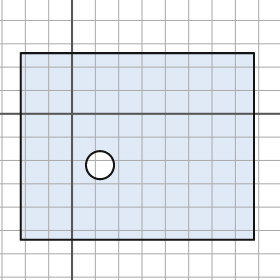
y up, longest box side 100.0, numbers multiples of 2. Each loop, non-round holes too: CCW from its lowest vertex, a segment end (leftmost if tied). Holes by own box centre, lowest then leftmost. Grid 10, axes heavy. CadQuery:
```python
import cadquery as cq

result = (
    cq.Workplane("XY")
    .moveTo(-22.0, -54.0)
    .lineTo(78.0, -54.0)
    .lineTo(78.0, 26.0)
    .lineTo(-22.0, 26.0)
    .close()
    .moveTo(12.0, -22.0)
    .circle(6.0)
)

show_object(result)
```